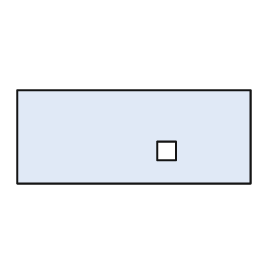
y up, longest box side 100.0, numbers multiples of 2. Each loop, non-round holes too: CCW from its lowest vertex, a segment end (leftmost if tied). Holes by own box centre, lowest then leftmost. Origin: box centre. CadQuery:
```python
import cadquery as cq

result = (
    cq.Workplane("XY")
    .moveTo(-50.0, -20.0)
    .lineTo(50.0, -20.0)
    .lineTo(50.0, 20.0)
    .lineTo(-50.0, 20.0)
    .close()
    .moveTo(10.0, -10.0)
    .lineTo(18.0, -10.0)
    .lineTo(18.0, -2.0)
    .lineTo(10.0, -2.0)
    .close()
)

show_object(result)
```